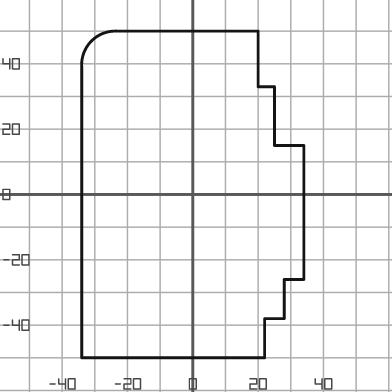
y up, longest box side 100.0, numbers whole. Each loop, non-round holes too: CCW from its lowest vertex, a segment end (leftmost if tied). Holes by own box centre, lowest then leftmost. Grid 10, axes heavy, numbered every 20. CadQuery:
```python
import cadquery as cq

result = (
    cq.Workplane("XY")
    .moveTo(-34.0, -50.0)
    .lineTo(22.0, -50.0)
    .lineTo(22.0, -38.0)
    .lineTo(28.0, -38.0)
    .lineTo(28.0, -26.0)
    .lineTo(34.0, -26.0)
    .lineTo(34.0, 15.0)
    .lineTo(25.0, 15.0)
    .lineTo(25.0, 33.0)
    .lineTo(20.0, 33.0)
    .lineTo(20.0, 50.0)
    .lineTo(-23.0, 50.0)
    .threePointArc((-31.0, 47.0), (-34.0, 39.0))
    .close()
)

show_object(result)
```